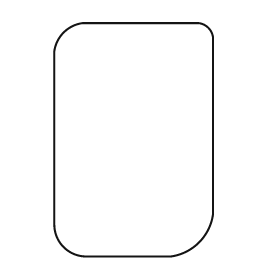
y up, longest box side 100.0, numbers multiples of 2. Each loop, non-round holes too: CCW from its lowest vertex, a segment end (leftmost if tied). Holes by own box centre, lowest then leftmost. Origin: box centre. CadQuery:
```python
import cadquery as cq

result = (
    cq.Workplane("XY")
    .moveTo(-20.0, -50.0)
    .lineTo(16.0, -50.0)
    .threePointArc((28.0, -44.0), (34.0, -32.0))
    .lineTo(34.0, 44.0)
    .threePointArc((32.0, 48.0), (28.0, 50.0))
    .lineTo(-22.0, 50.0)
    .threePointArc((-30.0, 46.0), (-34.0, 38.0))
    .lineTo(-34.0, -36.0)
    .threePointArc((-30.0, -46.0), (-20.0, -50.0))
    .close()
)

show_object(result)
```